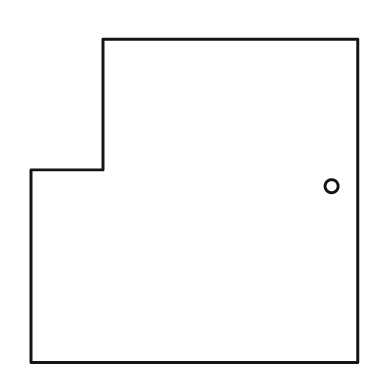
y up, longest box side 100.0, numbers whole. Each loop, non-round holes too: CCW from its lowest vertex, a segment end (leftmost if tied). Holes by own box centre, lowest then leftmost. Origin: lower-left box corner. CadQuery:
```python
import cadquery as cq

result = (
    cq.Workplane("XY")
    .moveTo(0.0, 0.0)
    .lineTo(100.0, 0.0)
    .lineTo(100.0, 99.0)
    .lineTo(22.0, 99.0)
    .lineTo(22.0, 59.0)
    .lineTo(0.0, 59.0)
    .close()
    .moveTo(92.0, 54.0)
    .circle(2.0)
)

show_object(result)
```